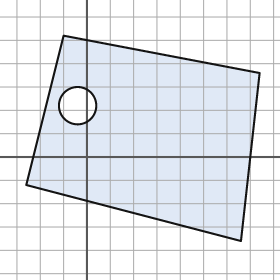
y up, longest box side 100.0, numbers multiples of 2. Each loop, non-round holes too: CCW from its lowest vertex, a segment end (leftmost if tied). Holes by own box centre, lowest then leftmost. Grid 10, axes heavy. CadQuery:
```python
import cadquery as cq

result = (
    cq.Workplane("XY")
    .moveTo(66.0, -36.0)
    .lineTo(74.0, 36.0)
    .lineTo(-10.0, 52.0)
    .lineTo(-26.0, -12.0)
    .close()
    .moveTo(-4.0, 22.0)
    .circle(8.0)
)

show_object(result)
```